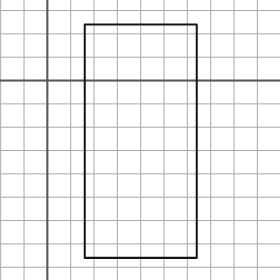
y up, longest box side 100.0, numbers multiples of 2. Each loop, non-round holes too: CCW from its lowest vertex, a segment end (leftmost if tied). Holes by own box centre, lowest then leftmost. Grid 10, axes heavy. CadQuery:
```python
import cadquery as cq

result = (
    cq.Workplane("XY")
    .moveTo(16.0, -76.0)
    .lineTo(64.0, -76.0)
    .lineTo(64.0, 24.0)
    .lineTo(16.0, 24.0)
    .close()
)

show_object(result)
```